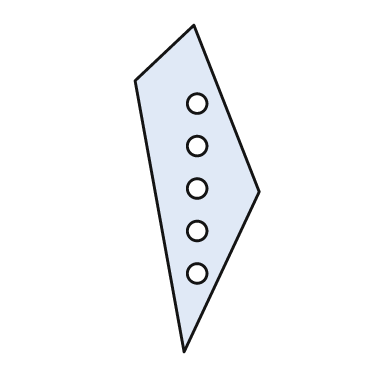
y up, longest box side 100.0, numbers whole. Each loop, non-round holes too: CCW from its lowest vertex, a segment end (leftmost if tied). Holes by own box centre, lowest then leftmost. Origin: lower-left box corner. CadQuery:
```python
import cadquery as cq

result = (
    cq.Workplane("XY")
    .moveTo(15.0, 0.0)
    .lineTo(38.0, 49.0)
    .lineTo(18.0, 100.0)
    .lineTo(0.0, 83.0)
    .close()
    .moveTo(19.0, 24.0)
    .circle(3.0)
    .moveTo(19.0, 37.0)
    .circle(3.0)
    .moveTo(19.0, 50.0)
    .circle(3.0)
    .moveTo(19.0, 63.0)
    .circle(3.0)
    .moveTo(19.0, 76.0)
    .circle(3.0)
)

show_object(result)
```